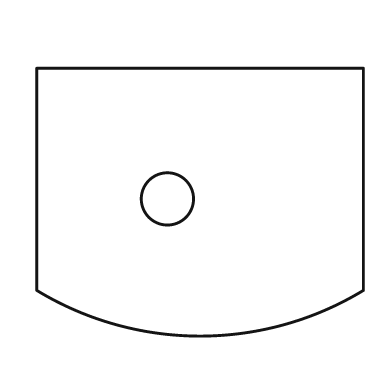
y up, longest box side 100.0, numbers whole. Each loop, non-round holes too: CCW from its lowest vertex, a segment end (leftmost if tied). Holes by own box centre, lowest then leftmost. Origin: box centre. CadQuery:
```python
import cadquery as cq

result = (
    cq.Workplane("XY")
    .moveTo(-50.0, -27.0)
    .threePointArc((0.0, -41.0), (50.0, -27.0))
    .lineTo(50.0, 41.0)
    .lineTo(-50.0, 41.0)
    .close()
    .moveTo(-10.0, 1.0)
    .circle(8.0)
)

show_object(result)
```